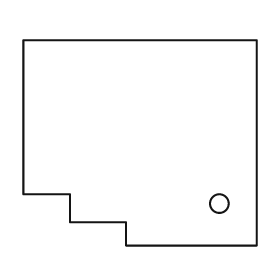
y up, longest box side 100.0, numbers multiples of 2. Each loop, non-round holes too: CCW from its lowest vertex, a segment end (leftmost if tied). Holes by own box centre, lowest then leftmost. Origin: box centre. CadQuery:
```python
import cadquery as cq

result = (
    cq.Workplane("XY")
    .moveTo(-6.0, -44.0)
    .lineTo(50.0, -44.0)
    .lineTo(50.0, 44.0)
    .lineTo(-50.0, 44.0)
    .lineTo(-50.0, -22.0)
    .lineTo(-30.0, -22.0)
    .lineTo(-30.0, -34.0)
    .lineTo(-6.0, -34.0)
    .close()
    .moveTo(34.0, -26.0)
    .circle(4.0)
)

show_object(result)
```